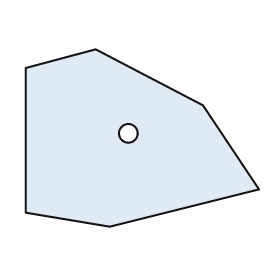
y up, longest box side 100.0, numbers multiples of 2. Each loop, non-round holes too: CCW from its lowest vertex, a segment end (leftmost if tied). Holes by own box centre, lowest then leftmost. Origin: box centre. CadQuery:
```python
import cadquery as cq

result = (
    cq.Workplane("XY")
    .moveTo(-14.0, -38.0)
    .lineTo(50.0, -22.0)
    .lineTo(26.0, 14.0)
    .lineTo(-20.0, 38.0)
    .lineTo(-50.0, 30.0)
    .lineTo(-50.0, -32.0)
    .close()
    .moveTo(-6.0, 2.0)
    .circle(4.0)
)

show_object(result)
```